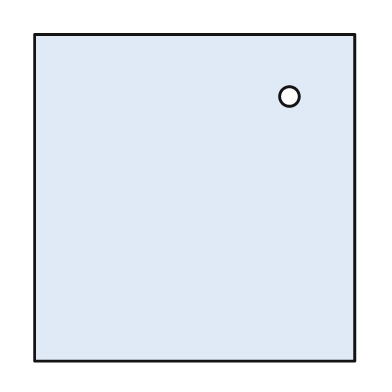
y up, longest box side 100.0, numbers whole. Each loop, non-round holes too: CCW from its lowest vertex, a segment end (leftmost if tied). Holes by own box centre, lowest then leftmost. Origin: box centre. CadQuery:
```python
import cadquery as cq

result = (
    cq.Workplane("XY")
    .moveTo(-49.0, -50.0)
    .lineTo(49.0, -50.0)
    .lineTo(49.0, 50.0)
    .lineTo(-49.0, 50.0)
    .close()
    .moveTo(29.0, 31.0)
    .circle(3.0)
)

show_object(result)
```